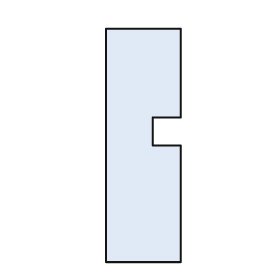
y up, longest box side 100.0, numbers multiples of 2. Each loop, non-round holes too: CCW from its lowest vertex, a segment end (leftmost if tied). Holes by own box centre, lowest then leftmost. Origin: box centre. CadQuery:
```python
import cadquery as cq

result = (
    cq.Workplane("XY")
    .moveTo(-16.0, -50.0)
    .lineTo(16.0, -50.0)
    .lineTo(16.0, 0.0)
    .lineTo(4.0, 0.0)
    .lineTo(4.0, 12.0)
    .lineTo(16.0, 12.0)
    .lineTo(16.0, 50.0)
    .lineTo(-16.0, 50.0)
    .close()
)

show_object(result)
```